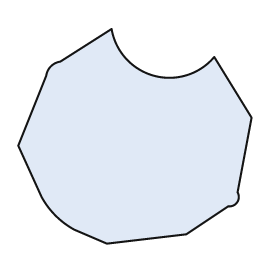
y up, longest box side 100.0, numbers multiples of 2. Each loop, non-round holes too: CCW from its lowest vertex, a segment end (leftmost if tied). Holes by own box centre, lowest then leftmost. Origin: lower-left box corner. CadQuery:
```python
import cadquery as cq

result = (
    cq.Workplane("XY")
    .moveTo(38.0, 0.0)
    .lineTo(72.0, 4.0)
    .lineTo(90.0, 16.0)
    .threePointArc((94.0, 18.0), (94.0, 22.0))
    .lineTo(100.0, 54.0)
    .lineTo(84.0, 80.0)
    .threePointArc((58.0, 72.0), (40.0, 92.0))
    .lineTo(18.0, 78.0)
    .threePointArc((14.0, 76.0), (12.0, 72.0))
    .lineTo(0.0, 42.0)
    .lineTo(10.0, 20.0)
    .threePointArc((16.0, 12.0), (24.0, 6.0))
    .close()
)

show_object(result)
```